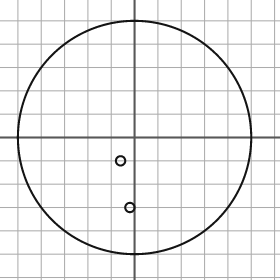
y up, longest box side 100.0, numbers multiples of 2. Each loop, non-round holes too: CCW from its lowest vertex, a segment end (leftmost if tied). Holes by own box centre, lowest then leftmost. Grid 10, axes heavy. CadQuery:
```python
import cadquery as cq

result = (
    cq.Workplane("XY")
    .moveTo(0.0, 0.0)
    .circle(50.0)
    .moveTo(-2.0, -30.0)
    .circle(2.0)
    .moveTo(-6.0, -10.0)
    .circle(2.0)
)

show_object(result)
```